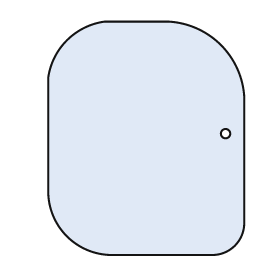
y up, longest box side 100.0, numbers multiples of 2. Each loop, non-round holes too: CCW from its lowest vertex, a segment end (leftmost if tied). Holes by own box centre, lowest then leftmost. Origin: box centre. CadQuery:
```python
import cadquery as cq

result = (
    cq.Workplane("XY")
    .moveTo(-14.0, -50.0)
    .lineTo(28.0, -50.0)
    .threePointArc((38.0, -46.0), (42.0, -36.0))
    .lineTo(42.0, 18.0)
    .threePointArc((32.0, 40.0), (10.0, 50.0))
    .lineTo(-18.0, 50.0)
    .threePointArc((-34.0, 42.0), (-42.0, 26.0))
    .lineTo(-42.0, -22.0)
    .threePointArc((-34.0, -42.0), (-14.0, -50.0))
    .close()
    .moveTo(34.0, 2.0)
    .circle(2.0)
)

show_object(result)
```